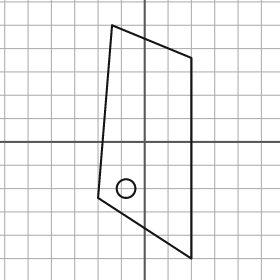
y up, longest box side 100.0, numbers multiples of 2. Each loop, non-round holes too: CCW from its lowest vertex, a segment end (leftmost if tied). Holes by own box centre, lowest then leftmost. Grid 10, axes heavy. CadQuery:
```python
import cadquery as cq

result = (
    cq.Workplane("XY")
    .moveTo(20.0, -50.0)
    .lineTo(20.0, 36.0)
    .lineTo(-14.0, 50.0)
    .lineTo(-20.0, -24.0)
    .close()
    .moveTo(-8.0, -20.0)
    .circle(4.0)
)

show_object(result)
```